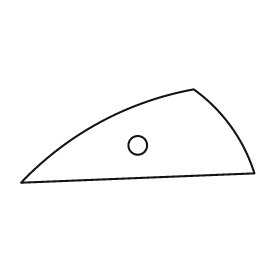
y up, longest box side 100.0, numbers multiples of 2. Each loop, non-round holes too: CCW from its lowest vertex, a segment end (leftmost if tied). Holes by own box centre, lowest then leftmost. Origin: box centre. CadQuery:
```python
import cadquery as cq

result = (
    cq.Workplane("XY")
    .moveTo(-50.0, -20.0)
    .lineTo(50.0, -16.0)
    .threePointArc((40.0, 4.0), (24.0, 20.0))
    .threePointArc((-16.0, 6.0), (-50.0, -20.0))
    .close()
    .moveTo(0.0, -4.0)
    .circle(4.0)
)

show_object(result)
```